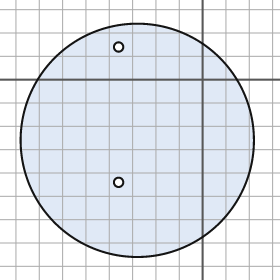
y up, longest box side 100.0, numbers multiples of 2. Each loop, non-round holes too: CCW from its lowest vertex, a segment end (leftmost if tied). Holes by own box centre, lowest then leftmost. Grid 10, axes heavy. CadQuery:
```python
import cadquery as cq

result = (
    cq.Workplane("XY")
    .moveTo(-28.0, -26.0)
    .circle(50.0)
    .moveTo(-36.0, -44.0)
    .circle(2.0)
    .moveTo(-36.0, 14.0)
    .circle(2.0)
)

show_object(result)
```